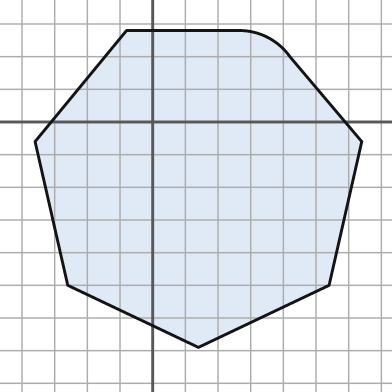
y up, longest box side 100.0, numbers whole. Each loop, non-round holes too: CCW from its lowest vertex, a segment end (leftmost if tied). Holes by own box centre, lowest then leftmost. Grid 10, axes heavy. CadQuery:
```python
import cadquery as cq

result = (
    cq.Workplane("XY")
    .moveTo(14.0, -69.0)
    .lineTo(54.0, -50.0)
    .lineTo(64.0, -6.0)
    .lineTo(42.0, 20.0)
    .threePointArc((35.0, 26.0), (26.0, 28.0))
    .lineTo(-8.0, 28.0)
    .lineTo(-36.0, -6.0)
    .lineTo(-26.0, -50.0)
    .close()
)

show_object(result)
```